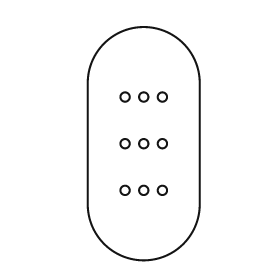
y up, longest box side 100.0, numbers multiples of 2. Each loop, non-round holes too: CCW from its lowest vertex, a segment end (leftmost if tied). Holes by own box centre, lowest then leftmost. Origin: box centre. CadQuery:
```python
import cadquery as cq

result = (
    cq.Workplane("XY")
    .moveTo(-24.0, -26.0)
    .threePointArc((0.0, -50.0), (24.0, -26.0))
    .lineTo(24.0, 26.0)
    .threePointArc((0.0, 50.0), (-24.0, 26.0))
    .close()
    .moveTo(-8.0, -20.0)
    .circle(2.0)
    .moveTo(0.0, -20.0)
    .circle(2.0)
    .moveTo(8.0, -20.0)
    .circle(2.0)
    .moveTo(-8.0, 0.0)
    .circle(2.0)
    .moveTo(0.0, 0.0)
    .circle(2.0)
    .moveTo(8.0, 0.0)
    .circle(2.0)
    .moveTo(-8.0, 20.0)
    .circle(2.0)
    .moveTo(0.0, 20.0)
    .circle(2.0)
    .moveTo(8.0, 20.0)
    .circle(2.0)
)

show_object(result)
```